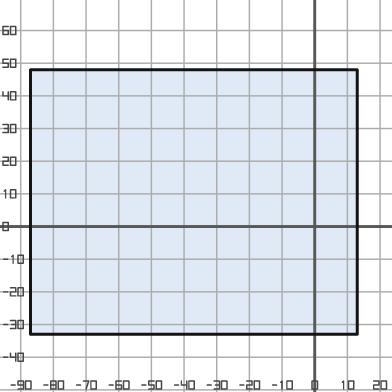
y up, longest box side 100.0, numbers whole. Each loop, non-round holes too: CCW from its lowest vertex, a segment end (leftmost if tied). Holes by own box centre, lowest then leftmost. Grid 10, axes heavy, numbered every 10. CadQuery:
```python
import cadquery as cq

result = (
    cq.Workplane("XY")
    .moveTo(-87.0, -33.0)
    .lineTo(13.0, -33.0)
    .lineTo(13.0, 48.0)
    .lineTo(-87.0, 48.0)
    .close()
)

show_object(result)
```